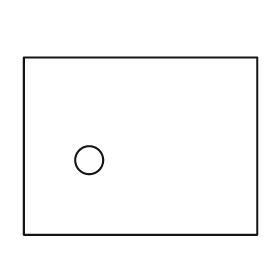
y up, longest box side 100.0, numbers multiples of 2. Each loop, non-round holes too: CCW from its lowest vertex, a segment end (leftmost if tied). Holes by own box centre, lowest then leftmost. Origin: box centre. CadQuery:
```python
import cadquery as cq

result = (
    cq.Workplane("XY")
    .moveTo(-50.0, -38.0)
    .lineTo(50.0, -38.0)
    .lineTo(50.0, 38.0)
    .lineTo(-50.0, 38.0)
    .close()
    .moveTo(-22.0, -6.0)
    .circle(6.0)
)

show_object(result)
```